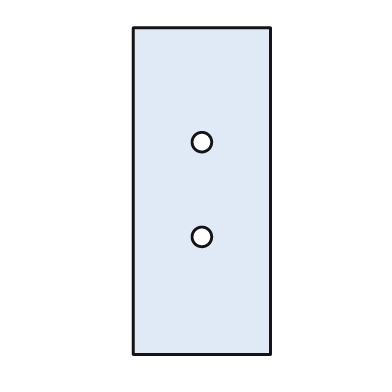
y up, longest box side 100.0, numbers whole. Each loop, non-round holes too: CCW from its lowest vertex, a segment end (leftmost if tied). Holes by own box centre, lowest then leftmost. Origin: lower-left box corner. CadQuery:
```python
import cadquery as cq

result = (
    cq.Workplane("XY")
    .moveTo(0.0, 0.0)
    .lineTo(42.0, 0.0)
    .lineTo(42.0, 100.0)
    .lineTo(0.0, 100.0)
    .close()
    .moveTo(21.0, 36.0)
    .circle(3.0)
    .moveTo(21.0, 65.0)
    .circle(3.0)
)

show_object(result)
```